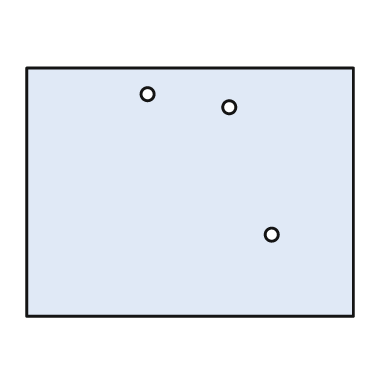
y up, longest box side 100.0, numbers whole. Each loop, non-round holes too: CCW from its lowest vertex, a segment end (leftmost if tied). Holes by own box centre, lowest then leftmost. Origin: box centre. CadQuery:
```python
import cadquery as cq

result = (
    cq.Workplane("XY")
    .moveTo(-50.0, -38.0)
    .lineTo(50.0, -38.0)
    .lineTo(50.0, 38.0)
    .lineTo(-50.0, 38.0)
    .close()
    .moveTo(25.0, -13.0)
    .circle(2.0)
    .moveTo(12.0, 26.0)
    .circle(2.0)
    .moveTo(-13.0, 30.0)
    .circle(2.0)
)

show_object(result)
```